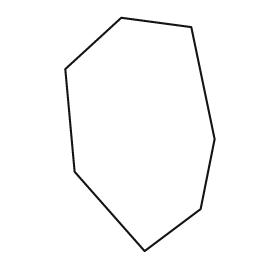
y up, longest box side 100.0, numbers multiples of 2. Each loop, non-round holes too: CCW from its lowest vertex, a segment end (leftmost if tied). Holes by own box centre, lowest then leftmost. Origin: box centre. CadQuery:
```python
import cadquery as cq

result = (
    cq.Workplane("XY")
    .moveTo(2.0, -50.0)
    .lineTo(26.0, -32.0)
    .lineTo(32.0, -2.0)
    .lineTo(22.0, 46.0)
    .lineTo(-8.0, 50.0)
    .lineTo(-32.0, 28.0)
    .lineTo(-28.0, -16.0)
    .close()
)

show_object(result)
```